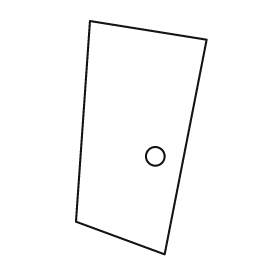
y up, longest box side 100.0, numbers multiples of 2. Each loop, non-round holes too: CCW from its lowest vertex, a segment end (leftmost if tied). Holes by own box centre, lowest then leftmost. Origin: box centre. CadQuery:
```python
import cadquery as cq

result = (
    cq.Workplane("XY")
    .moveTo(10.0, -50.0)
    .lineTo(28.0, 42.0)
    .lineTo(-22.0, 50.0)
    .lineTo(-28.0, -36.0)
    .close()
    .moveTo(6.0, -8.0)
    .circle(4.0)
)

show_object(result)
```